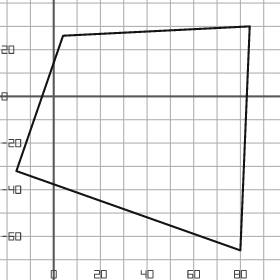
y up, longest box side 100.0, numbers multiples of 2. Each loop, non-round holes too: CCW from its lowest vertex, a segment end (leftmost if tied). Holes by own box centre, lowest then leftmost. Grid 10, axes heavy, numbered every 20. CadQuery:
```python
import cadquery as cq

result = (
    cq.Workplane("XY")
    .moveTo(80.0, -66.0)
    .lineTo(84.0, 30.0)
    .lineTo(4.0, 26.0)
    .lineTo(-16.0, -32.0)
    .close()
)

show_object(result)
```